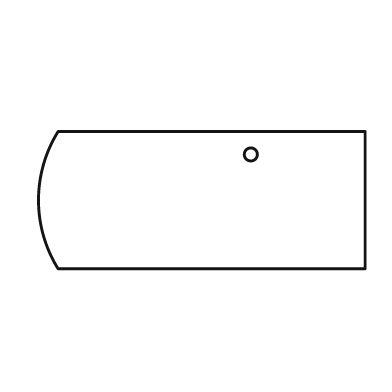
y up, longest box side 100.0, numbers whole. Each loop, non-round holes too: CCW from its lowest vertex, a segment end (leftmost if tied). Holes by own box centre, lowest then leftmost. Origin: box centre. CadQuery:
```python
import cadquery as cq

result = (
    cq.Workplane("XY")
    .moveTo(-44.0, -21.0)
    .lineTo(50.0, -21.0)
    .lineTo(50.0, 21.0)
    .lineTo(-44.0, 21.0)
    .threePointArc((-50.0, 0.0), (-44.0, -21.0))
    .close()
    .moveTo(15.0, 14.0)
    .circle(2.0)
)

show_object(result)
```